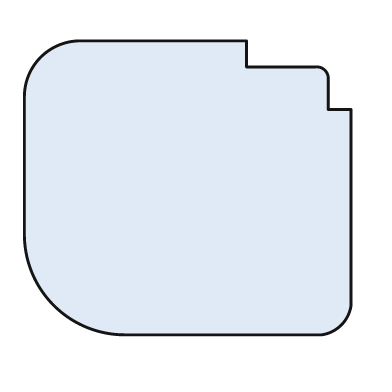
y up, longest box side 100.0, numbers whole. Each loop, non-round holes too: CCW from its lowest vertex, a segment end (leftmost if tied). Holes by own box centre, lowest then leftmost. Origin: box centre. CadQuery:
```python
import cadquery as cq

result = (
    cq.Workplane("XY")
    .moveTo(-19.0, -45.0)
    .lineTo(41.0, -45.0)
    .threePointArc((47.0, -42.0), (50.0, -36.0))
    .lineTo(50.0, 24.0)
    .lineTo(43.0, 24.0)
    .lineTo(43.0, 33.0)
    .threePointArc((42.0, 36.0), (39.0, 37.0))
    .lineTo(18.0, 37.0)
    .lineTo(18.0, 45.0)
    .lineTo(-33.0, 45.0)
    .threePointArc((-45.0, 40.0), (-50.0, 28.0))
    .lineTo(-50.0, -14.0)
    .threePointArc((-41.0, -36.0), (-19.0, -45.0))
    .close()
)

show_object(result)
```